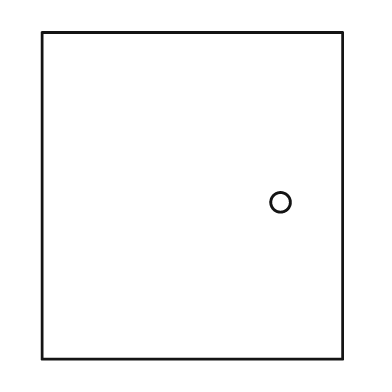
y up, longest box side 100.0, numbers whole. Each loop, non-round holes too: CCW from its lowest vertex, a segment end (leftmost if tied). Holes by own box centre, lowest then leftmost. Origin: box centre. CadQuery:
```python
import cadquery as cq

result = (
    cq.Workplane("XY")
    .moveTo(-46.0, -50.0)
    .lineTo(46.0, -50.0)
    .lineTo(46.0, 50.0)
    .lineTo(-46.0, 50.0)
    .close()
    .moveTo(27.0, -2.0)
    .circle(3.0)
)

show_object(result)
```